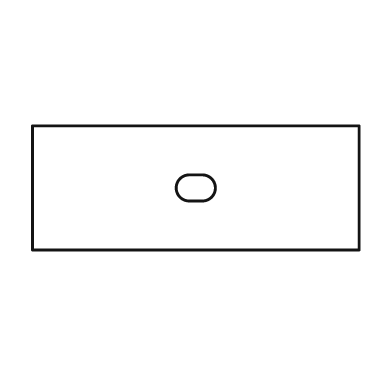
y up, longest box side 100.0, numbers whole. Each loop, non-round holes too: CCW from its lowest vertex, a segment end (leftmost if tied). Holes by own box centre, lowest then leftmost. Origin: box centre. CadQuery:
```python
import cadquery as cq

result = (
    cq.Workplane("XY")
    .moveTo(-50.0, -19.0)
    .lineTo(50.0, -19.0)
    .lineTo(50.0, 19.0)
    .lineTo(-50.0, 19.0)
    .close()
    .moveTo(-2.0, -4.0)
    .lineTo(2.0, -4.0)
    .threePointArc((6.0, 0.0), (2.0, 4.0))
    .lineTo(-2.0, 4.0)
    .threePointArc((-6.0, 0.0), (-2.0, -4.0))
    .close()
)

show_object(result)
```